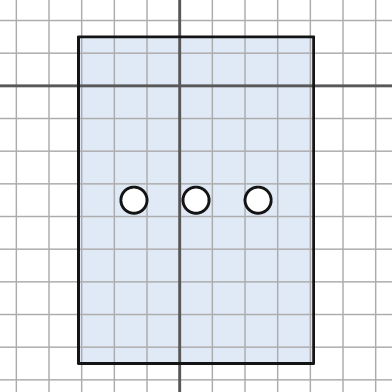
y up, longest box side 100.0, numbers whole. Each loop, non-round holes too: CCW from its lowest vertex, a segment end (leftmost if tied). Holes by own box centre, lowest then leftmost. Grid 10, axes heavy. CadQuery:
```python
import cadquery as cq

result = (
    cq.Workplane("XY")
    .moveTo(-31.0, -85.0)
    .lineTo(41.0, -85.0)
    .lineTo(41.0, 15.0)
    .lineTo(-31.0, 15.0)
    .close()
    .moveTo(-14.0, -35.0)
    .circle(4.0)
    .moveTo(5.0, -35.0)
    .circle(4.0)
    .moveTo(24.0, -35.0)
    .circle(4.0)
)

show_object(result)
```